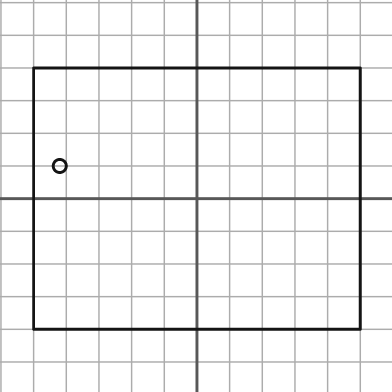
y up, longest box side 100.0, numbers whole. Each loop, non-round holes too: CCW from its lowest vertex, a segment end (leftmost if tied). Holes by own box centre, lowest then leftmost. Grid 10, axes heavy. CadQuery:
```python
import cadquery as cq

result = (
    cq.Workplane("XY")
    .moveTo(-50.0, -40.0)
    .lineTo(50.0, -40.0)
    .lineTo(50.0, 40.0)
    .lineTo(-50.0, 40.0)
    .close()
    .moveTo(-42.0, 10.0)
    .circle(2.0)
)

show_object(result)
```